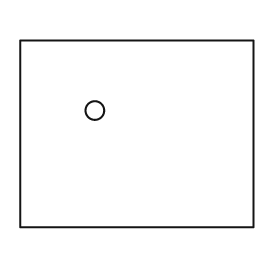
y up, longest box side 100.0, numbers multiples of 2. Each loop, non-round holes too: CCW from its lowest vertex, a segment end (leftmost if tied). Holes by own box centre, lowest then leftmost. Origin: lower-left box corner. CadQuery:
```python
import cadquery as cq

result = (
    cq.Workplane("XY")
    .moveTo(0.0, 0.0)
    .lineTo(100.0, 0.0)
    .lineTo(100.0, 80.0)
    .lineTo(0.0, 80.0)
    .close()
    .moveTo(32.0, 50.0)
    .circle(4.0)
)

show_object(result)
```